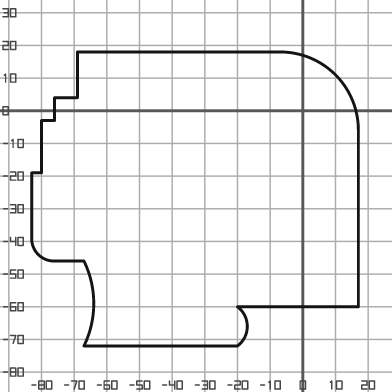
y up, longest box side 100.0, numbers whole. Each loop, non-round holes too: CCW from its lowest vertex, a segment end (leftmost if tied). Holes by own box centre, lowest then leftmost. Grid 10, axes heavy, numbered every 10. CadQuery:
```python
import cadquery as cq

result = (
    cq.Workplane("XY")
    .moveTo(-67.0, -72.0)
    .lineTo(-20.0, -72.0)
    .threePointArc((-17.0, -66.0), (-20.0, -60.0))
    .lineTo(17.0, -60.0)
    .lineTo(17.0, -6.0)
    .threePointArc((10.0, 11.0), (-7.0, 18.0))
    .lineTo(-69.0, 18.0)
    .lineTo(-69.0, 4.0)
    .lineTo(-76.0, 4.0)
    .lineTo(-76.0, -3.0)
    .lineTo(-80.0, -3.0)
    .lineTo(-80.0, -19.0)
    .lineTo(-83.0, -19.0)
    .lineTo(-83.0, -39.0)
    .threePointArc((-81.0, -44.0), (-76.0, -46.0))
    .lineTo(-67.0, -46.0)
    .threePointArc((-64.0, -59.0), (-67.0, -72.0))
    .close()
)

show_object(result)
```